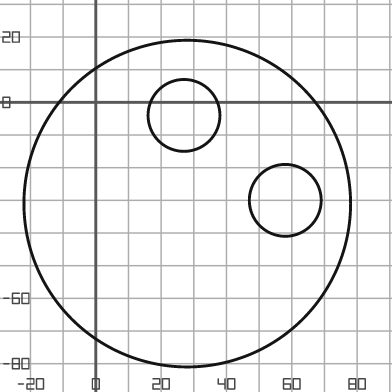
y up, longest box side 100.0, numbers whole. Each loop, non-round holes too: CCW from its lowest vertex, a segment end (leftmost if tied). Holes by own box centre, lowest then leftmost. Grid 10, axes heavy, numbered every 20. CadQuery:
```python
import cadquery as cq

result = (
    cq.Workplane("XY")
    .moveTo(28.0, -31.0)
    .circle(50.0)
    .moveTo(58.0, -30.0)
    .circle(11.0)
    .moveTo(27.0, -4.0)
    .circle(11.0)
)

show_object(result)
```